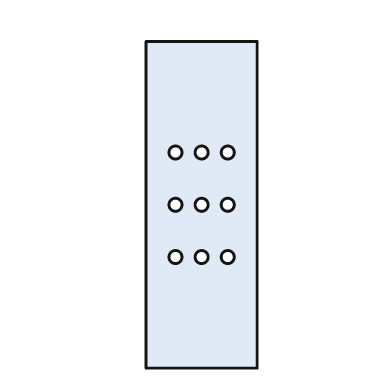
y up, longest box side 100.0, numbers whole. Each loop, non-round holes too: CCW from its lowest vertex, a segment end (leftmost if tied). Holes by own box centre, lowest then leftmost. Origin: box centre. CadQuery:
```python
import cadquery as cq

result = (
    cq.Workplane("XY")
    .moveTo(-17.0, -50.0)
    .lineTo(17.0, -50.0)
    .lineTo(17.0, 50.0)
    .lineTo(-17.0, 50.0)
    .close()
    .moveTo(-8.0, -16.0)
    .circle(2.0)
    .moveTo(0.0, -16.0)
    .circle(2.0)
    .moveTo(8.0, -16.0)
    .circle(2.0)
    .moveTo(-8.0, 0.0)
    .circle(2.0)
    .moveTo(0.0, 0.0)
    .circle(2.0)
    .moveTo(8.0, 0.0)
    .circle(2.0)
    .moveTo(-8.0, 16.0)
    .circle(2.0)
    .moveTo(0.0, 16.0)
    .circle(2.0)
    .moveTo(8.0, 16.0)
    .circle(2.0)
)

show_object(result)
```